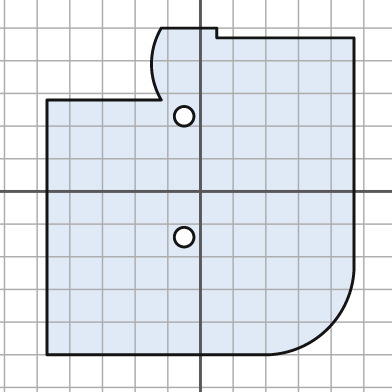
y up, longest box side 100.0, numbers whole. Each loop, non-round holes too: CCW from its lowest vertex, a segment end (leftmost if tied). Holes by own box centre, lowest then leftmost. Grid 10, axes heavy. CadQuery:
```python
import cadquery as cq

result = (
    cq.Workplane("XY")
    .moveTo(-47.0, -50.0)
    .lineTo(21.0, -50.0)
    .threePointArc((39.0, -42.0), (47.0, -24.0))
    .lineTo(47.0, 47.0)
    .lineTo(5.0, 47.0)
    .lineTo(5.0, 50.0)
    .lineTo(-12.0, 50.0)
    .threePointArc((-15.0, 39.0), (-12.0, 28.0))
    .lineTo(-47.0, 28.0)
    .close()
    .moveTo(-5.0, -14.0)
    .circle(3.0)
    .moveTo(-5.0, 23.0)
    .circle(3.0)
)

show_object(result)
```